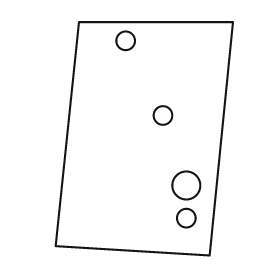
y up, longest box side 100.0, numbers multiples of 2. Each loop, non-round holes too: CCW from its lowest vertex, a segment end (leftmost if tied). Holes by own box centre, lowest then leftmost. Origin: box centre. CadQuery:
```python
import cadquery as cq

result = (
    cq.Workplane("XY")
    .moveTo(28.0, -50.0)
    .lineTo(38.0, 50.0)
    .lineTo(-28.0, 50.0)
    .lineTo(-38.0, -46.0)
    .close()
    .moveTo(18.0, -34.0)
    .circle(4.0)
    .moveTo(18.0, -20.0)
    .circle(6.0)
    .moveTo(8.0, 10.0)
    .circle(4.0)
    .moveTo(-8.0, 42.0)
    .circle(4.0)
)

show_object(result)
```